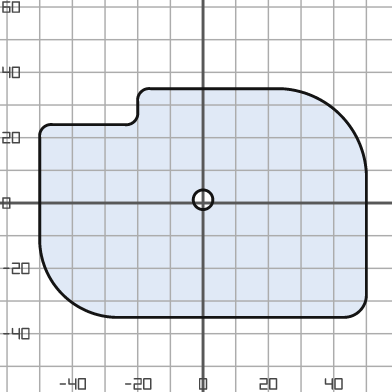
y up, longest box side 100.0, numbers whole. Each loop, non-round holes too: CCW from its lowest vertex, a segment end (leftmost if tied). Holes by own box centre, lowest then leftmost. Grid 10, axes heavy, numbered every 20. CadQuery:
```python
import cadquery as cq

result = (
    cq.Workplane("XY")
    .moveTo(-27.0, -35.0)
    .lineTo(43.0, -35.0)
    .threePointArc((48.0, -33.0), (50.0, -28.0))
    .lineTo(50.0, 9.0)
    .threePointArc((42.0, 27.0), (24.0, 35.0))
    .lineTo(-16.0, 35.0)
    .threePointArc((-19.0, 34.0), (-20.0, 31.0))
    .lineTo(-20.0, 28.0)
    .threePointArc((-21.0, 25.0), (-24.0, 24.0))
    .lineTo(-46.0, 24.0)
    .threePointArc((-49.0, 23.0), (-50.0, 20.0))
    .lineTo(-50.0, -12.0)
    .threePointArc((-43.0, -28.0), (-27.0, -35.0))
    .close()
    .moveTo(0.0, 1.0)
    .circle(3.0)
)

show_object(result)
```